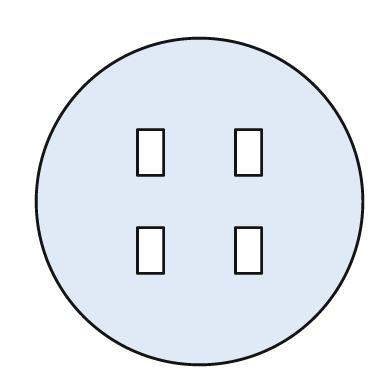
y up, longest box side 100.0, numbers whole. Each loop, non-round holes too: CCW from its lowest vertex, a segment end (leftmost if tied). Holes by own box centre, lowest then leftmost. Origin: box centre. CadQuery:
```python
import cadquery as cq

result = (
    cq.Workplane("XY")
    .moveTo(0.0, 0.0)
    .circle(50.0)
    .moveTo(-19.0, -22.0)
    .lineTo(-11.0, -22.0)
    .lineTo(-11.0, -8.0)
    .lineTo(-19.0, -8.0)
    .close()
    .moveTo(11.0, -22.0)
    .lineTo(19.0, -22.0)
    .lineTo(19.0, -8.0)
    .lineTo(11.0, -8.0)
    .close()
    .moveTo(-19.0, 8.0)
    .lineTo(-11.0, 8.0)
    .lineTo(-11.0, 22.0)
    .lineTo(-19.0, 22.0)
    .close()
    .moveTo(11.0, 8.0)
    .lineTo(19.0, 8.0)
    .lineTo(19.0, 22.0)
    .lineTo(11.0, 22.0)
    .close()
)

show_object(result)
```